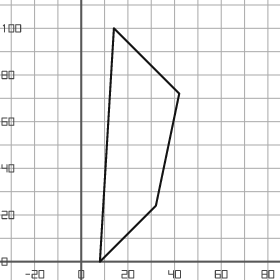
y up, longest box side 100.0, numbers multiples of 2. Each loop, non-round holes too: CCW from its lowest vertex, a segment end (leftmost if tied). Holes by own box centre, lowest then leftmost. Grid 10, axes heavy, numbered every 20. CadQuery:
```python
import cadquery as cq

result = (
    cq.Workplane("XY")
    .moveTo(8.0, 0.0)
    .lineTo(32.0, 24.0)
    .lineTo(42.0, 72.0)
    .lineTo(14.0, 100.0)
    .close()
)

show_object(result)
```